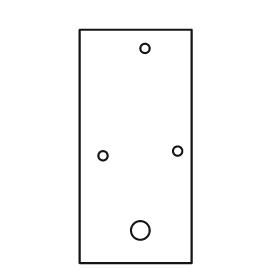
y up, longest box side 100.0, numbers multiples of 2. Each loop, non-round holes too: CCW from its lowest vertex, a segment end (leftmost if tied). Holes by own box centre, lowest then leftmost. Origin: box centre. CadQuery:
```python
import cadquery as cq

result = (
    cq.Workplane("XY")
    .moveTo(-24.0, -50.0)
    .lineTo(24.0, -50.0)
    .lineTo(24.0, 50.0)
    .lineTo(-24.0, 50.0)
    .close()
    .moveTo(2.0, -36.0)
    .circle(4.0)
    .moveTo(-14.0, -4.0)
    .circle(2.0)
    .moveTo(18.0, -2.0)
    .circle(2.0)
    .moveTo(4.0, 42.0)
    .circle(2.0)
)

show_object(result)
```